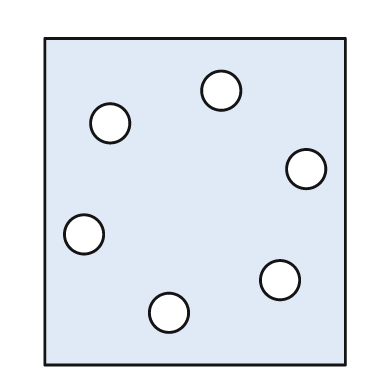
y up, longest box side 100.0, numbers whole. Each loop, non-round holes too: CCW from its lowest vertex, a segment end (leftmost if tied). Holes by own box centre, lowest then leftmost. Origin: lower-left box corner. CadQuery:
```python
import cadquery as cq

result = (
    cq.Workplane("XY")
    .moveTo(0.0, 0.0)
    .lineTo(92.0, 0.0)
    .lineTo(92.0, 100.0)
    .lineTo(0.0, 100.0)
    .close()
    .moveTo(38.0, 16.0)
    .circle(6.0)
    .moveTo(72.0, 26.0)
    .circle(6.0)
    .moveTo(12.0, 40.0)
    .circle(6.0)
    .moveTo(80.0, 60.0)
    .circle(6.0)
    .moveTo(20.0, 74.0)
    .circle(6.0)
    .moveTo(54.0, 84.0)
    .circle(6.0)
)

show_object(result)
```